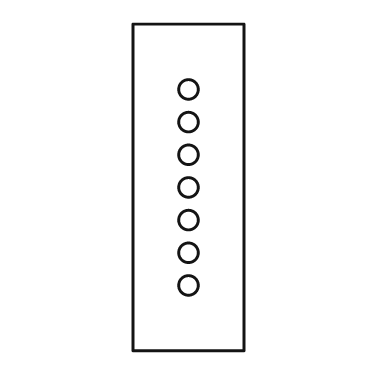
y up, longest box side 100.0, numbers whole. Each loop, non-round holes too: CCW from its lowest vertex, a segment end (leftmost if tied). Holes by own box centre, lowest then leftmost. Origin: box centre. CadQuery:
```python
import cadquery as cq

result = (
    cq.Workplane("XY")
    .moveTo(-17.0, -50.0)
    .lineTo(17.0, -50.0)
    .lineTo(17.0, 50.0)
    .lineTo(-17.0, 50.0)
    .close()
    .moveTo(0.0, -30.0)
    .circle(3.0)
    .moveTo(0.0, -20.0)
    .circle(3.0)
    .moveTo(0.0, -10.0)
    .circle(3.0)
    .moveTo(0.0, 0.0)
    .circle(3.0)
    .moveTo(0.0, 10.0)
    .circle(3.0)
    .moveTo(0.0, 20.0)
    .circle(3.0)
    .moveTo(0.0, 30.0)
    .circle(3.0)
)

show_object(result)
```